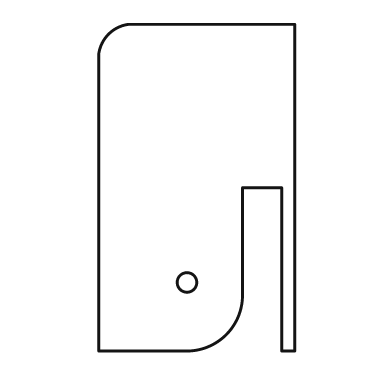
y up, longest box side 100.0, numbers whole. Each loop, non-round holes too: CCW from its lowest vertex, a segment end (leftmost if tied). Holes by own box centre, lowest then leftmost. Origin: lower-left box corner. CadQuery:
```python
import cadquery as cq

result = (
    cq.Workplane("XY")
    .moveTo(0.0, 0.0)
    .lineTo(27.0, 0.0)
    .threePointArc((39.0, 5.0), (44.0, 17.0))
    .lineTo(44.0, 50.0)
    .lineTo(56.0, 50.0)
    .lineTo(56.0, 0.0)
    .lineTo(60.0, 0.0)
    .lineTo(60.0, 100.0)
    .lineTo(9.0, 100.0)
    .threePointArc((3.0, 97.0), (0.0, 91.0))
    .close()
    .moveTo(27.0, 21.0)
    .circle(3.0)
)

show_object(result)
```